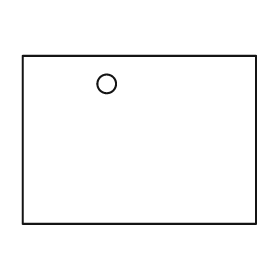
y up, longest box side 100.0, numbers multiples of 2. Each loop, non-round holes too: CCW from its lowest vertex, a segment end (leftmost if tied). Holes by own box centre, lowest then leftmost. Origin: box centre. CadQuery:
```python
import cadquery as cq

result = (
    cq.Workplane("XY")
    .moveTo(-50.0, -36.0)
    .lineTo(50.0, -36.0)
    .lineTo(50.0, 36.0)
    .lineTo(-50.0, 36.0)
    .close()
    .moveTo(-14.0, 24.0)
    .circle(4.0)
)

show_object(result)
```